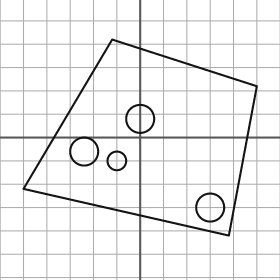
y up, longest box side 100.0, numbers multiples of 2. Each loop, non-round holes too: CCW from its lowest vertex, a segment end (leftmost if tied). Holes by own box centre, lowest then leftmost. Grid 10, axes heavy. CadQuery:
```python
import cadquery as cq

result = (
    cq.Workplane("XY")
    .moveTo(38.0, -42.0)
    .lineTo(50.0, 22.0)
    .lineTo(-12.0, 42.0)
    .lineTo(-50.0, -22.0)
    .close()
    .moveTo(30.0, -30.0)
    .circle(6.0)
    .moveTo(-10.0, -10.0)
    .circle(4.0)
    .moveTo(-24.0, -6.0)
    .circle(6.0)
    .moveTo(0.0, 8.0)
    .circle(6.0)
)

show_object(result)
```